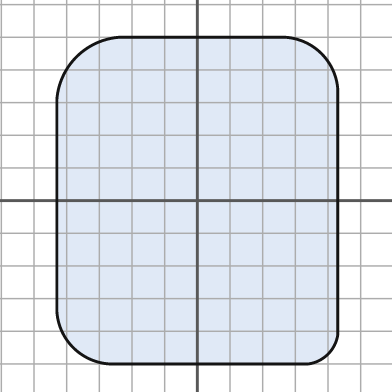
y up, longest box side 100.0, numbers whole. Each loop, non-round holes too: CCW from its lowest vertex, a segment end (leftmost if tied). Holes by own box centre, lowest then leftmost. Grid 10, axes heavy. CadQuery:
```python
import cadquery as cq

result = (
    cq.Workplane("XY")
    .moveTo(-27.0, -50.0)
    .lineTo(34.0, -50.0)
    .threePointArc((40.0, -47.0), (43.0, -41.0))
    .lineTo(43.0, 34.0)
    .threePointArc((38.0, 45.0), (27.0, 50.0))
    .lineTo(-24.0, 50.0)
    .threePointArc((-37.0, 44.0), (-43.0, 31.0))
    .lineTo(-43.0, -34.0)
    .threePointArc((-38.0, -45.0), (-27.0, -50.0))
    .close()
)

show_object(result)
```